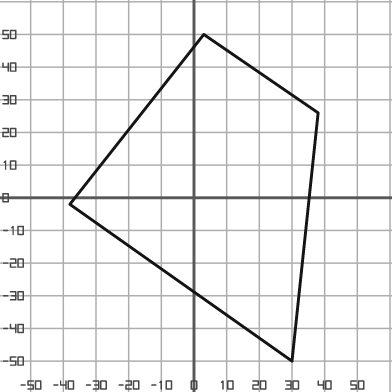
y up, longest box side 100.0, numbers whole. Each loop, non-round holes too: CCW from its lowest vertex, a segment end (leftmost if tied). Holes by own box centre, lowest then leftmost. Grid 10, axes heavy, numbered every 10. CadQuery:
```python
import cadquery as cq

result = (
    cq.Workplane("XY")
    .moveTo(30.0, -50.0)
    .lineTo(38.0, 26.0)
    .lineTo(3.0, 50.0)
    .lineTo(-38.0, -2.0)
    .close()
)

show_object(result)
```